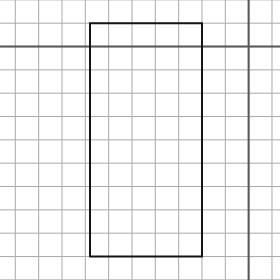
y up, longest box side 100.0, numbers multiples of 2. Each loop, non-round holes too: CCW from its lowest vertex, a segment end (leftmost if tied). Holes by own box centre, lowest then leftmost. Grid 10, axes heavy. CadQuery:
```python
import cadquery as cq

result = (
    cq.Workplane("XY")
    .moveTo(-68.0, -90.0)
    .lineTo(-20.0, -90.0)
    .lineTo(-20.0, 10.0)
    .lineTo(-68.0, 10.0)
    .close()
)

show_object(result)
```